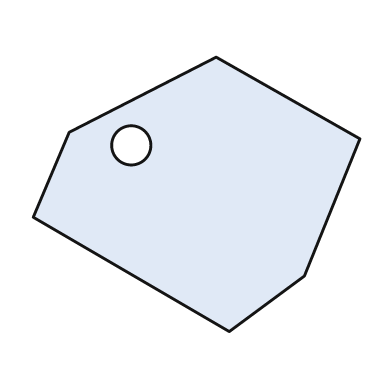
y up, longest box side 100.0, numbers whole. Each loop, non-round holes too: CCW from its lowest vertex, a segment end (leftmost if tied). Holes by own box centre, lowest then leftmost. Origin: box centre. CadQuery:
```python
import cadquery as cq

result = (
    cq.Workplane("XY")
    .moveTo(10.0, -42.0)
    .lineTo(33.0, -25.0)
    .lineTo(50.0, 17.0)
    .lineTo(6.0, 42.0)
    .lineTo(-39.0, 19.0)
    .lineTo(-50.0, -7.0)
    .close()
    .moveTo(-20.0, 15.0)
    .circle(6.0)
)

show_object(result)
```